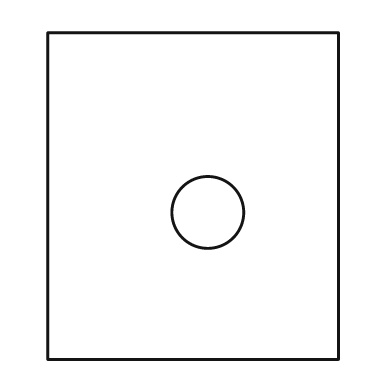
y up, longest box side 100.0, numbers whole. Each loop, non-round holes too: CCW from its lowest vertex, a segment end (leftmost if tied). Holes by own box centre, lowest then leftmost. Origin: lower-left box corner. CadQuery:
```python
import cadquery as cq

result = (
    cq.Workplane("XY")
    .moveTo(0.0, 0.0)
    .lineTo(89.0, 0.0)
    .lineTo(89.0, 100.0)
    .lineTo(0.0, 100.0)
    .close()
    .moveTo(49.0, 45.0)
    .circle(11.0)
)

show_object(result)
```